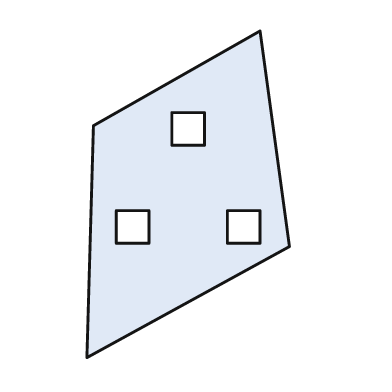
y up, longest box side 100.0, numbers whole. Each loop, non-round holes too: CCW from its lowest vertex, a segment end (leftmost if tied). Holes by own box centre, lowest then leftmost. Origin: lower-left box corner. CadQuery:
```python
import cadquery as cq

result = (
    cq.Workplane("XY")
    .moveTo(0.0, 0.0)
    .lineTo(62.0, 34.0)
    .lineTo(53.0, 100.0)
    .lineTo(2.0, 71.0)
    .close()
    .moveTo(9.0, 35.0)
    .lineTo(19.0, 35.0)
    .lineTo(19.0, 45.0)
    .lineTo(9.0, 45.0)
    .close()
    .moveTo(43.0, 35.0)
    .lineTo(53.0, 35.0)
    .lineTo(53.0, 45.0)
    .lineTo(43.0, 45.0)
    .close()
    .moveTo(26.0, 65.0)
    .lineTo(36.0, 65.0)
    .lineTo(36.0, 75.0)
    .lineTo(26.0, 75.0)
    .close()
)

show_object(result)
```